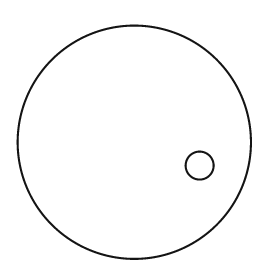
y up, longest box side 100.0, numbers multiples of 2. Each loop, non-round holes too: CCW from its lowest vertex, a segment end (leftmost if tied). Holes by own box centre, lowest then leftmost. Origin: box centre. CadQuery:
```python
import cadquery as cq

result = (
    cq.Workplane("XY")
    .moveTo(0.0, 0.0)
    .circle(50.0)
    .moveTo(28.0, -10.0)
    .circle(6.0)
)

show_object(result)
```